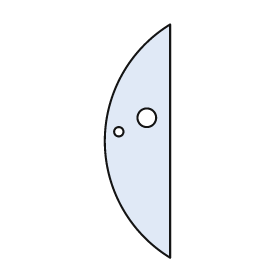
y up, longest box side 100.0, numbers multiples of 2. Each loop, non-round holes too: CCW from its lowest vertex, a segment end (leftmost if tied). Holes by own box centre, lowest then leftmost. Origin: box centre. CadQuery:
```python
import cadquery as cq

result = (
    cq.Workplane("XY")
    .moveTo(14.0, -50.0)
    .lineTo(14.0, 50.0)
    .threePointArc((-14.0, 0.0), (14.0, -50.0))
    .close()
    .moveTo(-8.0, 4.0)
    .circle(2.0)
    .moveTo(4.0, 10.0)
    .circle(4.0)
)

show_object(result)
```